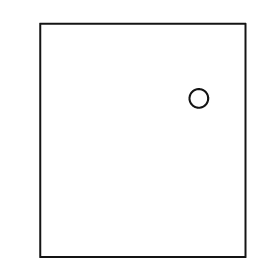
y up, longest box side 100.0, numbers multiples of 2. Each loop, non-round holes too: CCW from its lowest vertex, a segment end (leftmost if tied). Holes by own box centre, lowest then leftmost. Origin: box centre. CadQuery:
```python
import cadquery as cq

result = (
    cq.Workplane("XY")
    .moveTo(-44.0, -50.0)
    .lineTo(44.0, -50.0)
    .lineTo(44.0, 50.0)
    .lineTo(-44.0, 50.0)
    .close()
    .moveTo(24.0, 18.0)
    .circle(4.0)
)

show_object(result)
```